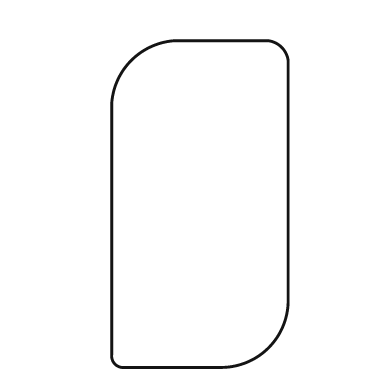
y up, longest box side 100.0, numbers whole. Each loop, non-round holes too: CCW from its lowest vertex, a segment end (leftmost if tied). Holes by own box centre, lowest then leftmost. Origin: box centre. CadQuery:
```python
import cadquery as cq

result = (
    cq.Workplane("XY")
    .moveTo(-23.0, -50.0)
    .lineTo(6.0, -50.0)
    .threePointArc((21.0, -44.0), (27.0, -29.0))
    .lineTo(27.0, 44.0)
    .threePointArc((25.0, 48.0), (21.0, 50.0))
    .lineTo(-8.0, 50.0)
    .threePointArc((-21.0, 44.0), (-27.0, 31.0))
    .lineTo(-27.0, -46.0)
    .threePointArc((-26.0, -49.0), (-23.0, -50.0))
    .close()
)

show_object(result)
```